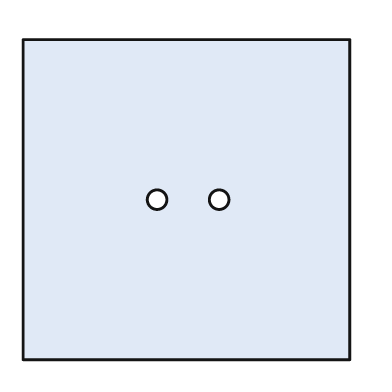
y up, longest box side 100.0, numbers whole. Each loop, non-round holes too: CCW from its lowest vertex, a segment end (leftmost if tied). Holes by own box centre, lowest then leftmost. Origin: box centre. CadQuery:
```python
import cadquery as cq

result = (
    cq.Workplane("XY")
    .moveTo(-50.0, -49.0)
    .lineTo(50.0, -49.0)
    .lineTo(50.0, 49.0)
    .lineTo(-50.0, 49.0)
    .close()
    .moveTo(-9.0, 0.0)
    .circle(3.0)
    .moveTo(10.0, 0.0)
    .circle(3.0)
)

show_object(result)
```